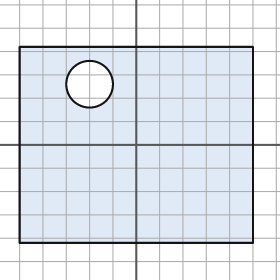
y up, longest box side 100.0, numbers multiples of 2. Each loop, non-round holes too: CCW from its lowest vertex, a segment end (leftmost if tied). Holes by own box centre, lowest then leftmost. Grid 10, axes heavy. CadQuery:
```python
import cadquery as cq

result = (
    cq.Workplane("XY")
    .moveTo(-50.0, -42.0)
    .lineTo(50.0, -42.0)
    .lineTo(50.0, 42.0)
    .lineTo(-50.0, 42.0)
    .close()
    .moveTo(-20.0, 26.0)
    .circle(10.0)
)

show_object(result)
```